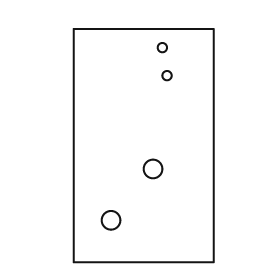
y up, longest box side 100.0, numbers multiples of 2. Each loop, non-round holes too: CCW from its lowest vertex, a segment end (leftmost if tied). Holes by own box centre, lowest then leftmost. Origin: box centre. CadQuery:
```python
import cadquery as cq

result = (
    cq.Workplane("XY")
    .moveTo(-30.0, -50.0)
    .lineTo(30.0, -50.0)
    .lineTo(30.0, 50.0)
    .lineTo(-30.0, 50.0)
    .close()
    .moveTo(-14.0, -32.0)
    .circle(4.0)
    .moveTo(4.0, -10.0)
    .circle(4.0)
    .moveTo(10.0, 30.0)
    .circle(2.0)
    .moveTo(8.0, 42.0)
    .circle(2.0)
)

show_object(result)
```